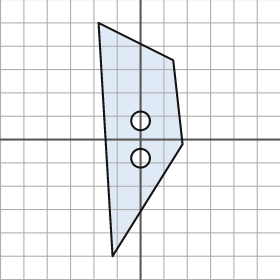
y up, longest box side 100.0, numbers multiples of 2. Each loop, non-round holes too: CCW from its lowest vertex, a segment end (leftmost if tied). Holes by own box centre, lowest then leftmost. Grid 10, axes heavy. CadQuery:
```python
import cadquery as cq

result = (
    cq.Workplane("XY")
    .moveTo(-12.0, -50.0)
    .lineTo(18.0, -2.0)
    .lineTo(14.0, 34.0)
    .lineTo(-18.0, 50.0)
    .close()
    .moveTo(0.0, -8.0)
    .circle(4.0)
    .moveTo(0.0, 8.0)
    .circle(4.0)
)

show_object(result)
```